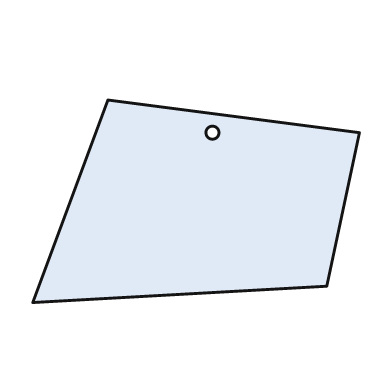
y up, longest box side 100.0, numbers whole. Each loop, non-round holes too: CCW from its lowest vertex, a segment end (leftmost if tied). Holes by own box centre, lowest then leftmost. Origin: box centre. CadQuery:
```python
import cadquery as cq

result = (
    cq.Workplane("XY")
    .moveTo(-50.0, -31.0)
    .lineTo(40.0, -26.0)
    .lineTo(50.0, 21.0)
    .lineTo(-27.0, 31.0)
    .close()
    .moveTo(5.0, 21.0)
    .circle(2.0)
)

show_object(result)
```